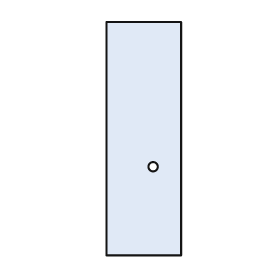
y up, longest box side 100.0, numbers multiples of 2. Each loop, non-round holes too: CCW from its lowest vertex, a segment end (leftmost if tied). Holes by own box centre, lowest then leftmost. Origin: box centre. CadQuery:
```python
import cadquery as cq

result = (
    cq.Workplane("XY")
    .moveTo(-16.0, -50.0)
    .lineTo(16.0, -50.0)
    .lineTo(16.0, 50.0)
    .lineTo(-16.0, 50.0)
    .close()
    .moveTo(4.0, -12.0)
    .circle(2.0)
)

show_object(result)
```